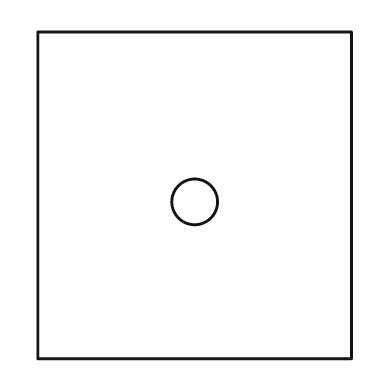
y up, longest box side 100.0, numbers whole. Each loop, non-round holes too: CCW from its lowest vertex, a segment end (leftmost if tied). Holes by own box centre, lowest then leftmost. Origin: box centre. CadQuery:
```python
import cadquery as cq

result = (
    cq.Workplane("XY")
    .moveTo(-48.0, -50.0)
    .lineTo(48.0, -50.0)
    .lineTo(48.0, 50.0)
    .lineTo(-48.0, 50.0)
    .close()
    .moveTo(0.0, -2.0)
    .circle(7.0)
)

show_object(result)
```